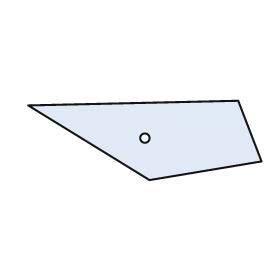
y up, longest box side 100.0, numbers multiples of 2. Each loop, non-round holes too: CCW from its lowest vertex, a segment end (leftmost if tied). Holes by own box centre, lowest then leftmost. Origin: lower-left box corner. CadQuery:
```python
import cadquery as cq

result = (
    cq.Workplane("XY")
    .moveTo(52.0, 0.0)
    .lineTo(100.0, 8.0)
    .lineTo(90.0, 34.0)
    .lineTo(0.0, 32.0)
    .close()
    .moveTo(50.0, 18.0)
    .circle(2.0)
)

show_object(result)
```